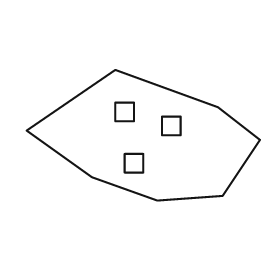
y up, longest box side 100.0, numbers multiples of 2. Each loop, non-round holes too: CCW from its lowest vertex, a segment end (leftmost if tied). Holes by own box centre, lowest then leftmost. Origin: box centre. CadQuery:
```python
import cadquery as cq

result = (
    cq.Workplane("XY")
    .moveTo(6.0, -28.0)
    .lineTo(34.0, -26.0)
    .lineTo(50.0, -2.0)
    .lineTo(32.0, 12.0)
    .lineTo(-12.0, 28.0)
    .lineTo(-50.0, 2.0)
    .lineTo(-22.0, -18.0)
    .close()
    .moveTo(-8.0, -16.0)
    .lineTo(0.0, -16.0)
    .lineTo(0.0, -8.0)
    .lineTo(-8.0, -8.0)
    .close()
    .moveTo(8.0, 0.0)
    .lineTo(16.0, 0.0)
    .lineTo(16.0, 8.0)
    .lineTo(8.0, 8.0)
    .close()
    .moveTo(-12.0, 6.0)
    .lineTo(-4.0, 6.0)
    .lineTo(-4.0, 14.0)
    .lineTo(-12.0, 14.0)
    .close()
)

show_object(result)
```